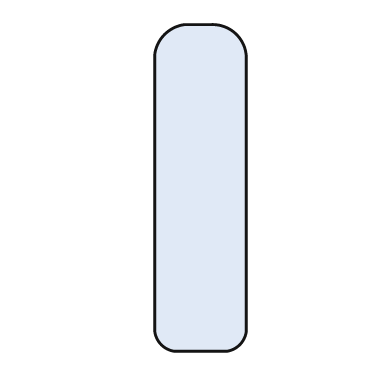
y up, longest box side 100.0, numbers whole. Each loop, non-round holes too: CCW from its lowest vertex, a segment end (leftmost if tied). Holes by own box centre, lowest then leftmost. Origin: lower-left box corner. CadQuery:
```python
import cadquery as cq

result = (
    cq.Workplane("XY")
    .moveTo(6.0, 0.0)
    .lineTo(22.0, 0.0)
    .threePointArc((26.0, 2.0), (28.0, 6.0))
    .lineTo(28.0, 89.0)
    .threePointArc((25.0, 97.0), (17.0, 100.0))
    .lineTo(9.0, 100.0)
    .threePointArc((3.0, 97.0), (0.0, 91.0))
    .lineTo(0.0, 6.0)
    .threePointArc((2.0, 2.0), (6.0, 0.0))
    .close()
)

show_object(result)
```